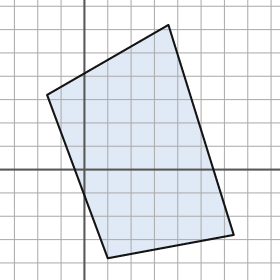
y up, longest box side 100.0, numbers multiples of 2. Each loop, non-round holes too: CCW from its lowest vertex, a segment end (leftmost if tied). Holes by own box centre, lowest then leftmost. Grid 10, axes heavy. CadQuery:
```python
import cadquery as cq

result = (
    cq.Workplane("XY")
    .moveTo(10.0, -38.0)
    .lineTo(64.0, -28.0)
    .lineTo(36.0, 62.0)
    .lineTo(-16.0, 32.0)
    .close()
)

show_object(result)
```